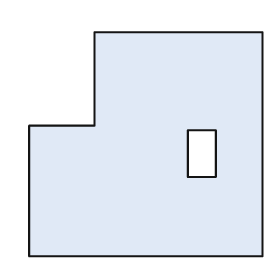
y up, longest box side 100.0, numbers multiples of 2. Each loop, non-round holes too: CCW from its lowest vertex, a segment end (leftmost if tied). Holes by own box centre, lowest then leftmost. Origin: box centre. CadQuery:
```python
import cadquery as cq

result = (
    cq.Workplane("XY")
    .moveTo(-50.0, -48.0)
    .lineTo(50.0, -48.0)
    .lineTo(50.0, 48.0)
    .lineTo(-22.0, 48.0)
    .lineTo(-22.0, 8.0)
    .lineTo(-50.0, 8.0)
    .close()
    .moveTo(18.0, -14.0)
    .lineTo(30.0, -14.0)
    .lineTo(30.0, 6.0)
    .lineTo(18.0, 6.0)
    .close()
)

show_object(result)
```